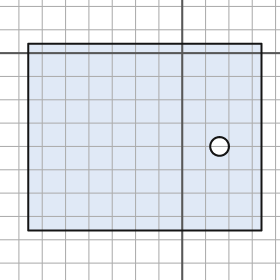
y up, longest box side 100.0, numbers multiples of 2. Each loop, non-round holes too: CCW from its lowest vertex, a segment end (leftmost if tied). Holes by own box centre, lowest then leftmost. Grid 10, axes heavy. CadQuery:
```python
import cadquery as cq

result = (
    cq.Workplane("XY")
    .moveTo(-66.0, -76.0)
    .lineTo(34.0, -76.0)
    .lineTo(34.0, 4.0)
    .lineTo(-66.0, 4.0)
    .close()
    .moveTo(16.0, -40.0)
    .circle(4.0)
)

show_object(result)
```